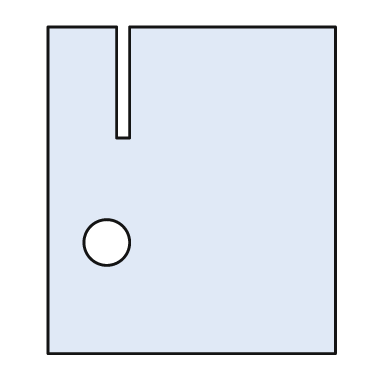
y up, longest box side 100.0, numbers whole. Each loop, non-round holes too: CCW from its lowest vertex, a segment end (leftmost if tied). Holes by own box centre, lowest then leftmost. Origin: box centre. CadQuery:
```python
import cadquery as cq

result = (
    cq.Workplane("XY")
    .moveTo(-44.0, -50.0)
    .lineTo(44.0, -50.0)
    .lineTo(44.0, 50.0)
    .lineTo(-19.0, 50.0)
    .lineTo(-19.0, 16.0)
    .lineTo(-23.0, 16.0)
    .lineTo(-23.0, 50.0)
    .lineTo(-44.0, 50.0)
    .close()
    .moveTo(-26.0, -16.0)
    .circle(7.0)
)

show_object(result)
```